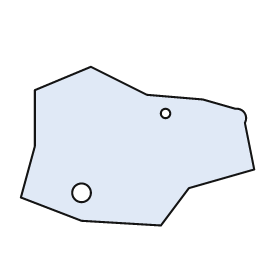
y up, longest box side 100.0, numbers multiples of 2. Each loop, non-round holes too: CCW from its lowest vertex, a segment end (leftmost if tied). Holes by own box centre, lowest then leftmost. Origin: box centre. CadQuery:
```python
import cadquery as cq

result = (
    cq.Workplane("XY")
    .moveTo(10.0, -34.0)
    .lineTo(22.0, -18.0)
    .lineTo(50.0, -10.0)
    .lineTo(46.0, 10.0)
    .threePointArc((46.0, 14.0), (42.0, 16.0))
    .lineTo(28.0, 20.0)
    .lineTo(4.0, 22.0)
    .lineTo(-20.0, 34.0)
    .lineTo(-44.0, 24.0)
    .lineTo(-44.0, 0.0)
    .lineTo(-50.0, -22.0)
    .lineTo(-24.0, -32.0)
    .close()
    .moveTo(-24.0, -20.0)
    .circle(4.0)
    .moveTo(12.0, 14.0)
    .circle(2.0)
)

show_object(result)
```